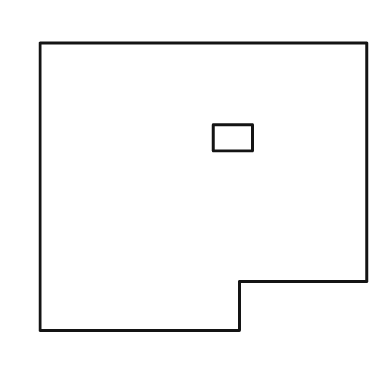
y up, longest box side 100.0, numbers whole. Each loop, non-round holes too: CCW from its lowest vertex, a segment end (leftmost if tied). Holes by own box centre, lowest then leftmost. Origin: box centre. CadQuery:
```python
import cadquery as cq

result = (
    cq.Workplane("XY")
    .moveTo(-50.0, -44.0)
    .lineTo(11.0, -44.0)
    .lineTo(11.0, -29.0)
    .lineTo(50.0, -29.0)
    .lineTo(50.0, 44.0)
    .lineTo(-50.0, 44.0)
    .close()
    .moveTo(3.0, 11.0)
    .lineTo(15.0, 11.0)
    .lineTo(15.0, 19.0)
    .lineTo(3.0, 19.0)
    .close()
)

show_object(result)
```